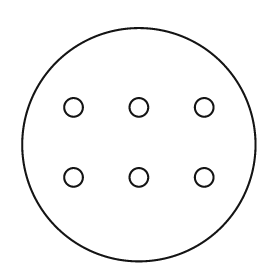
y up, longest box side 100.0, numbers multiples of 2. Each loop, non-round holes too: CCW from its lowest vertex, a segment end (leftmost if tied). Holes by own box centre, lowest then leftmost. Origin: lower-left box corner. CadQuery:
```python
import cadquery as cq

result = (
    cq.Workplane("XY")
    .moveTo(50.0, 50.0)
    .circle(50.0)
    .moveTo(22.0, 36.0)
    .circle(4.0)
    .moveTo(50.0, 36.0)
    .circle(4.0)
    .moveTo(78.0, 36.0)
    .circle(4.0)
    .moveTo(22.0, 66.0)
    .circle(4.0)
    .moveTo(50.0, 66.0)
    .circle(4.0)
    .moveTo(78.0, 66.0)
    .circle(4.0)
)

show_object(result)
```